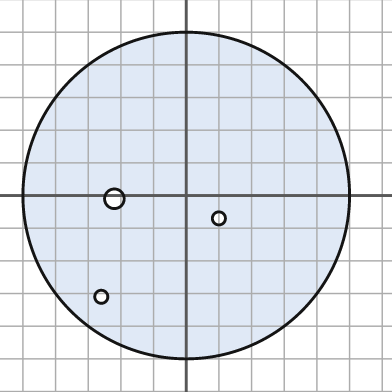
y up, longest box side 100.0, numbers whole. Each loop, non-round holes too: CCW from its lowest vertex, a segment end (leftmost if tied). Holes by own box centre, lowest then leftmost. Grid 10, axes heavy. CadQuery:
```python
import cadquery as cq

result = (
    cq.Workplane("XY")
    .moveTo(0.0, 0.0)
    .circle(50.0)
    .moveTo(-26.0, -31.0)
    .circle(2.0)
    .moveTo(10.0, -7.0)
    .circle(2.0)
    .moveTo(-22.0, -1.0)
    .circle(3.0)
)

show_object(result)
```